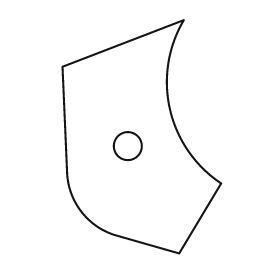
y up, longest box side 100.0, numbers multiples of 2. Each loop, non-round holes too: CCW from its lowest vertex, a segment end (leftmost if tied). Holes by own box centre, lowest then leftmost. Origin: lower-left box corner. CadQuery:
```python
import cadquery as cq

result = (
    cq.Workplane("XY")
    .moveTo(50.0, 0.0)
    .lineTo(68.0, 30.0)
    .threePointArc((46.0, 62.0), (52.0, 100.0))
    .lineTo(0.0, 80.0)
    .lineTo(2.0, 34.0)
    .threePointArc((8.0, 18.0), (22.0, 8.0))
    .close()
    .moveTo(28.0, 46.0)
    .circle(6.0)
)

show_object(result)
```